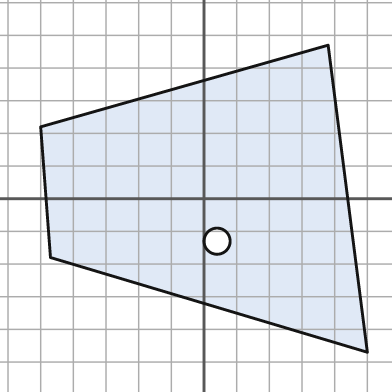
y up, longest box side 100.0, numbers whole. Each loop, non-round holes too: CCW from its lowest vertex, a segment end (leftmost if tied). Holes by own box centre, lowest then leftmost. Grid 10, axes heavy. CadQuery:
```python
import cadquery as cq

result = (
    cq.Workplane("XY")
    .moveTo(50.0, -47.0)
    .lineTo(38.0, 47.0)
    .lineTo(-50.0, 22.0)
    .lineTo(-47.0, -18.0)
    .close()
    .moveTo(4.0, -13.0)
    .circle(4.0)
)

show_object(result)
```